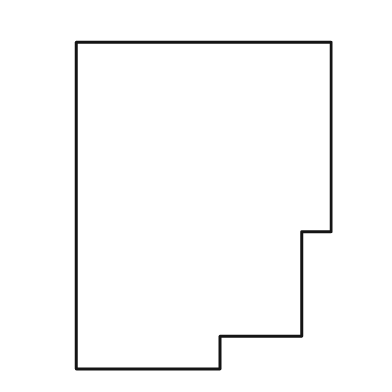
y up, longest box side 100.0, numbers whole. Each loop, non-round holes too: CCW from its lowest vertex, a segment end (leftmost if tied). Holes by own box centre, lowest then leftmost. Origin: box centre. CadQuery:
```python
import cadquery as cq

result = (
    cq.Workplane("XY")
    .moveTo(-39.0, -50.0)
    .lineTo(5.0, -50.0)
    .lineTo(5.0, -40.0)
    .lineTo(30.0, -40.0)
    .lineTo(30.0, -8.0)
    .lineTo(39.0, -8.0)
    .lineTo(39.0, 50.0)
    .lineTo(-39.0, 50.0)
    .close()
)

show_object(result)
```